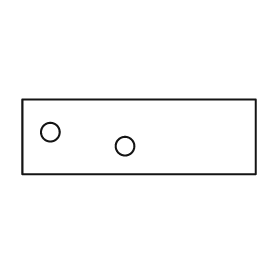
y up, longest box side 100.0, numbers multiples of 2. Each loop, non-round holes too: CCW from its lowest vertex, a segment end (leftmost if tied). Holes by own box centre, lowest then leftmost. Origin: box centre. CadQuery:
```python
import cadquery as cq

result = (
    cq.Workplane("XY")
    .moveTo(-50.0, -16.0)
    .lineTo(50.0, -16.0)
    .lineTo(50.0, 16.0)
    .lineTo(-50.0, 16.0)
    .close()
    .moveTo(-6.0, -4.0)
    .circle(4.0)
    .moveTo(-38.0, 2.0)
    .circle(4.0)
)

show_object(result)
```